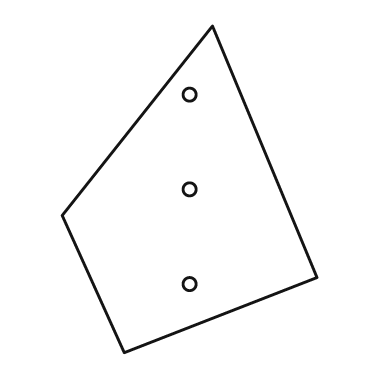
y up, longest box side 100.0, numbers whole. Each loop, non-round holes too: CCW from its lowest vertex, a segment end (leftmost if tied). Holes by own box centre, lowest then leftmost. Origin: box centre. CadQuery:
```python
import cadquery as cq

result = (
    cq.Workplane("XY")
    .moveTo(-20.0, -50.0)
    .lineTo(39.0, -27.0)
    .lineTo(7.0, 50.0)
    .lineTo(-39.0, -8.0)
    .close()
    .moveTo(0.0, -29.0)
    .circle(2.0)
    .moveTo(0.0, 0.0)
    .circle(2.0)
    .moveTo(0.0, 29.0)
    .circle(2.0)
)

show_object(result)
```